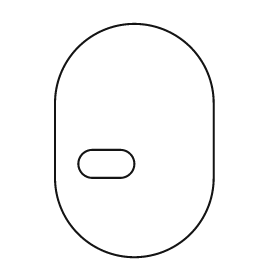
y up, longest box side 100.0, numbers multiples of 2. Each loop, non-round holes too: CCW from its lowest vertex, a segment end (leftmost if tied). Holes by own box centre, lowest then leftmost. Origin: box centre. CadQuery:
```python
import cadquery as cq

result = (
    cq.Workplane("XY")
    .moveTo(-34.0, -16.0)
    .threePointArc((0.0, -50.0), (34.0, -16.0))
    .lineTo(34.0, 16.0)
    .threePointArc((0.0, 50.0), (-34.0, 16.0))
    .close()
    .moveTo(-18.0, -16.0)
    .lineTo(-6.0, -16.0)
    .threePointArc((0.0, -10.0), (-6.0, -4.0))
    .lineTo(-18.0, -4.0)
    .threePointArc((-24.0, -10.0), (-18.0, -16.0))
    .close()
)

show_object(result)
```